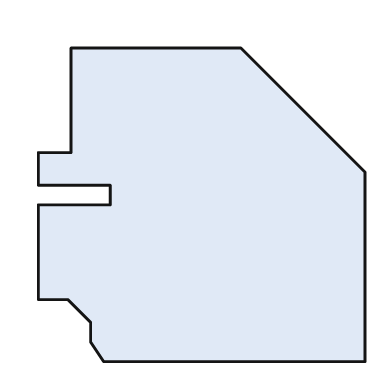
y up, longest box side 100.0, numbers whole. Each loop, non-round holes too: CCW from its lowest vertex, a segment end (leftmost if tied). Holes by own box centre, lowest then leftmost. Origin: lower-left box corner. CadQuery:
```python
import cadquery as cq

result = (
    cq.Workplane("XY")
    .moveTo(20.0, 0.0)
    .lineTo(100.0, 0.0)
    .lineTo(100.0, 58.0)
    .lineTo(62.0, 96.0)
    .lineTo(10.0, 96.0)
    .lineTo(10.0, 64.0)
    .lineTo(0.0, 64.0)
    .lineTo(0.0, 54.0)
    .lineTo(22.0, 54.0)
    .lineTo(22.0, 48.0)
    .lineTo(0.0, 48.0)
    .lineTo(0.0, 19.0)
    .lineTo(9.0, 19.0)
    .lineTo(16.0, 12.0)
    .lineTo(16.0, 6.0)
    .close()
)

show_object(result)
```